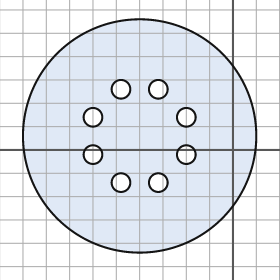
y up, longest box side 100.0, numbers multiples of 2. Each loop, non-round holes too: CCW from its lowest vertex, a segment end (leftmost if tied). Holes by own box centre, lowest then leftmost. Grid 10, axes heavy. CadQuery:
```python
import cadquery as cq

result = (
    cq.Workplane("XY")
    .moveTo(-40.0, 6.0)
    .circle(50.0)
    .moveTo(-48.0, -14.0)
    .circle(4.0)
    .moveTo(-32.0, -14.0)
    .circle(4.0)
    .moveTo(-60.0, -2.0)
    .circle(4.0)
    .moveTo(-20.0, -2.0)
    .circle(4.0)
    .moveTo(-60.0, 14.0)
    .circle(4.0)
    .moveTo(-20.0, 14.0)
    .circle(4.0)
    .moveTo(-48.0, 26.0)
    .circle(4.0)
    .moveTo(-32.0, 26.0)
    .circle(4.0)
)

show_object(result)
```